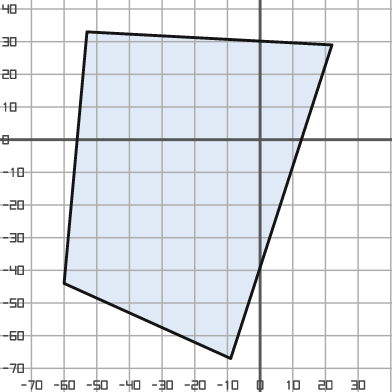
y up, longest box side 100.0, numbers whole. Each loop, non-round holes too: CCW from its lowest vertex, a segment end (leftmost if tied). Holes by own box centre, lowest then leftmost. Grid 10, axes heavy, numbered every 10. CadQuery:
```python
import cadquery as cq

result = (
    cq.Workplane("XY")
    .moveTo(-9.0, -67.0)
    .lineTo(22.0, 29.0)
    .lineTo(-53.0, 33.0)
    .lineTo(-60.0, -44.0)
    .close()
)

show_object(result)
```